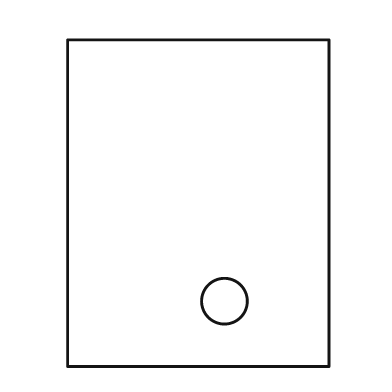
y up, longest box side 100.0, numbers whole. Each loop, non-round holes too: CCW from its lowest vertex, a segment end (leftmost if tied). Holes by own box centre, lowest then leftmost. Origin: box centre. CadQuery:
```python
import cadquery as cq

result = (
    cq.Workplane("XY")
    .moveTo(-40.0, -50.0)
    .lineTo(40.0, -50.0)
    .lineTo(40.0, 50.0)
    .lineTo(-40.0, 50.0)
    .close()
    .moveTo(8.0, -30.0)
    .circle(7.0)
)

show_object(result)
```